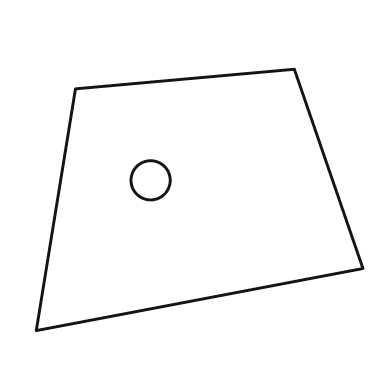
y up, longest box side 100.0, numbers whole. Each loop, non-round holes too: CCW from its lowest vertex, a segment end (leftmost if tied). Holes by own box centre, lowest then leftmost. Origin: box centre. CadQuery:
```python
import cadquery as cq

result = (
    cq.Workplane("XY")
    .moveTo(-50.0, -40.0)
    .lineTo(50.0, -21.0)
    .lineTo(29.0, 40.0)
    .lineTo(-38.0, 34.0)
    .close()
    .moveTo(-15.0, 6.0)
    .circle(6.0)
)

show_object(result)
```